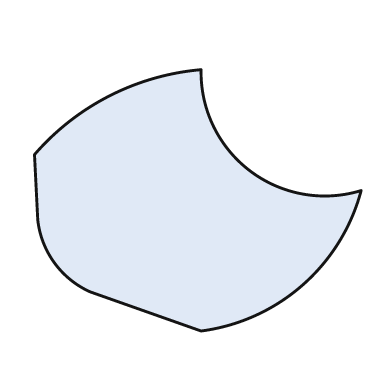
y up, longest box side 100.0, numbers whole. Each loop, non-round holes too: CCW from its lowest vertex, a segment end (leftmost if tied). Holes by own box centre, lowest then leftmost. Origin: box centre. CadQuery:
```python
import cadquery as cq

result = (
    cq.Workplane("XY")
    .moveTo(1.0, -40.0)
    .threePointArc((32.0, -26.0), (50.0, 3.0))
    .threePointArc((16.0, 9.0), (1.0, 40.0))
    .threePointArc((-27.0, 32.0), (-50.0, 14.0))
    .lineTo(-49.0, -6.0)
    .threePointArc((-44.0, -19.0), (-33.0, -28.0))
    .close()
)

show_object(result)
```